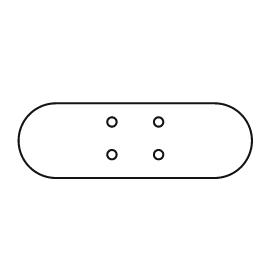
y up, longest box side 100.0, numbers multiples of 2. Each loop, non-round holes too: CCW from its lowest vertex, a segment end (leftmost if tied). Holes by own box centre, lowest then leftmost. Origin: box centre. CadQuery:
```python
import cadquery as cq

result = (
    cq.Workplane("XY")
    .moveTo(-34.0, -16.0)
    .lineTo(34.0, -16.0)
    .threePointArc((50.0, 0.0), (34.0, 16.0))
    .lineTo(-34.0, 16.0)
    .threePointArc((-50.0, 0.0), (-34.0, -16.0))
    .close()
    .moveTo(-10.0, -6.0)
    .circle(2.0)
    .moveTo(10.0, -6.0)
    .circle(2.0)
    .moveTo(-10.0, 8.0)
    .circle(2.0)
    .moveTo(10.0, 8.0)
    .circle(2.0)
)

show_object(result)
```